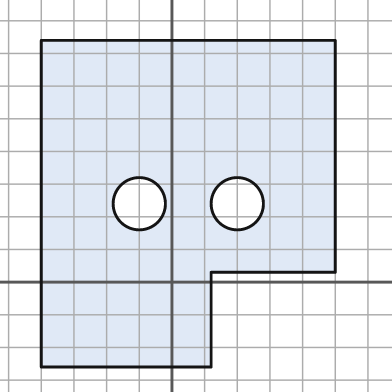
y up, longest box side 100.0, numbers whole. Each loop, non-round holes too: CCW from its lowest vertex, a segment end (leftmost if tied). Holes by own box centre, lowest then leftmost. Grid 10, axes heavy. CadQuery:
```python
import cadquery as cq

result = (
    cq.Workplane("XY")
    .moveTo(-40.0, -26.0)
    .lineTo(12.0, -26.0)
    .lineTo(12.0, 3.0)
    .lineTo(50.0, 3.0)
    .lineTo(50.0, 74.0)
    .lineTo(-40.0, 74.0)
    .close()
    .moveTo(-10.0, 24.0)
    .circle(8.0)
    .moveTo(20.0, 24.0)
    .circle(8.0)
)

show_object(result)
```